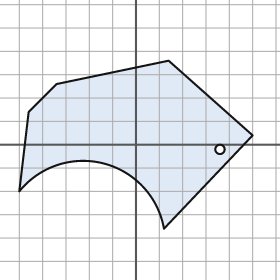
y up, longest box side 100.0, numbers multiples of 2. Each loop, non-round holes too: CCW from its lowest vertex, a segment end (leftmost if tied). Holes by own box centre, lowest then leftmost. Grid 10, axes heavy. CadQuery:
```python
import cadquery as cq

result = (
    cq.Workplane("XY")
    .moveTo(12.0, -36.0)
    .lineTo(50.0, 4.0)
    .lineTo(14.0, 36.0)
    .lineTo(-34.0, 26.0)
    .lineTo(-46.0, 14.0)
    .lineTo(-50.0, -20.0)
    .threePointArc((-14.0, -8.0), (12.0, -36.0))
    .close()
    .moveTo(36.0, -2.0)
    .circle(2.0)
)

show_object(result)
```